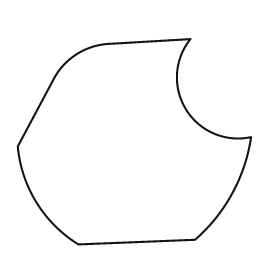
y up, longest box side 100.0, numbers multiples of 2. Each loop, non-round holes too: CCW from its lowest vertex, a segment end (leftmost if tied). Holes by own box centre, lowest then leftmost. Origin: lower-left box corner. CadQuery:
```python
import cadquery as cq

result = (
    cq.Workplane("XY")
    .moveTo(26.0, 0.0)
    .lineTo(76.0, 2.0)
    .threePointArc((92.0, 22.0), (100.0, 46.0))
    .threePointArc((72.0, 58.0), (74.0, 88.0))
    .lineTo(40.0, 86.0)
    .threePointArc((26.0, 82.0), (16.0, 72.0))
    .lineTo(0.0, 42.0)
    .threePointArc((8.0, 18.0), (26.0, 0.0))
    .close()
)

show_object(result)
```